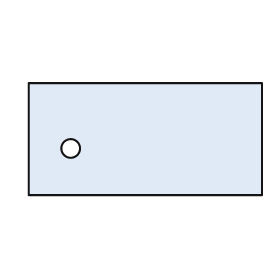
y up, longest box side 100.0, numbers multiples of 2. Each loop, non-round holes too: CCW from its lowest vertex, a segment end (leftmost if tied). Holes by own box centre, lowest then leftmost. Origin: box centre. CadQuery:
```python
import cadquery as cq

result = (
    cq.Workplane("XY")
    .moveTo(-50.0, -24.0)
    .lineTo(50.0, -24.0)
    .lineTo(50.0, 24.0)
    .lineTo(-50.0, 24.0)
    .close()
    .moveTo(-32.0, -4.0)
    .circle(4.0)
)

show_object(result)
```